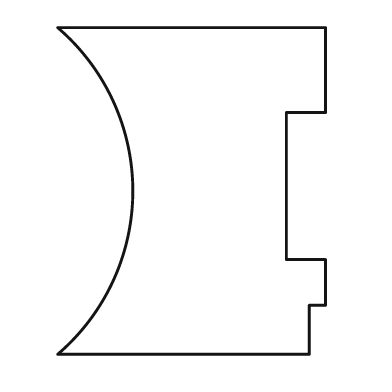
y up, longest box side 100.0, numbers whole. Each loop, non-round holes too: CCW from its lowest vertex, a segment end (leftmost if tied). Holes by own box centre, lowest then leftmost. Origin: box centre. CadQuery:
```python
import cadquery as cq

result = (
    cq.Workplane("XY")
    .moveTo(-41.0, -50.0)
    .lineTo(36.0, -50.0)
    .lineTo(36.0, -35.0)
    .lineTo(41.0, -35.0)
    .lineTo(41.0, -21.0)
    .lineTo(29.0, -21.0)
    .lineTo(29.0, 24.0)
    .lineTo(41.0, 24.0)
    .lineTo(41.0, 50.0)
    .lineTo(-41.0, 50.0)
    .threePointArc((-18.0, 0.0), (-41.0, -50.0))
    .close()
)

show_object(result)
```